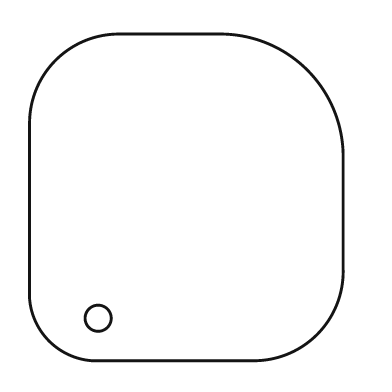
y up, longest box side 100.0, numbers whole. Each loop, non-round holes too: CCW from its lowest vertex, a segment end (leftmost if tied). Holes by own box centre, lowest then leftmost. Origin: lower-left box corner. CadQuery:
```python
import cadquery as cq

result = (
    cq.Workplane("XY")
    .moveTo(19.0, 0.0)
    .lineTo(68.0, 0.0)
    .threePointArc((88.0, 8.0), (96.0, 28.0))
    .lineTo(96.0, 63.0)
    .threePointArc((85.0, 89.0), (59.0, 100.0))
    .lineTo(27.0, 100.0)
    .threePointArc((8.0, 92.0), (0.0, 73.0))
    .lineTo(0.0, 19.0)
    .threePointArc((6.0, 6.0), (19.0, 0.0))
    .close()
    .moveTo(21.0, 13.0)
    .circle(4.0)
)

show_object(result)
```